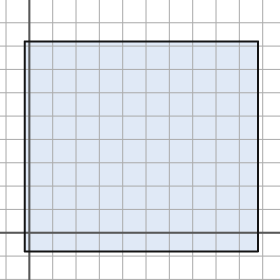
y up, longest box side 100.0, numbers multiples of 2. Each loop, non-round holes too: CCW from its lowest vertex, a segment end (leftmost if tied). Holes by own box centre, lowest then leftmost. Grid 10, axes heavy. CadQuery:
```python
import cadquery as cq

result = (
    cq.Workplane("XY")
    .moveTo(-2.0, -8.0)
    .lineTo(98.0, -8.0)
    .lineTo(98.0, 82.0)
    .lineTo(-2.0, 82.0)
    .close()
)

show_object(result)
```